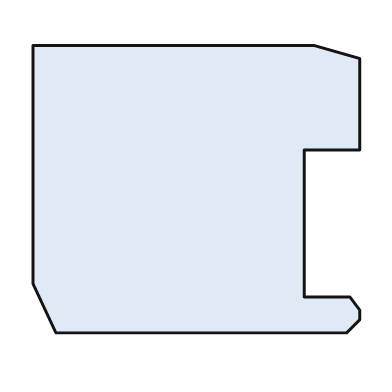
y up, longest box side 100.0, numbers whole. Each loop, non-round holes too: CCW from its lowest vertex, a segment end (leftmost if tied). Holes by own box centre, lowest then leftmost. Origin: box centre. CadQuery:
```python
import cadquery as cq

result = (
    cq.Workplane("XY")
    .moveTo(-43.0, -44.0)
    .lineTo(46.0, -44.0)
    .lineTo(50.0, -40.0)
    .lineTo(50.0, -37.0)
    .lineTo(47.0, -33.0)
    .lineTo(33.0, -33.0)
    .lineTo(33.0, 12.0)
    .lineTo(50.0, 12.0)
    .lineTo(50.0, 40.0)
    .lineTo(36.0, 44.0)
    .lineTo(-50.0, 44.0)
    .lineTo(-50.0, -29.0)
    .close()
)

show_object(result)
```